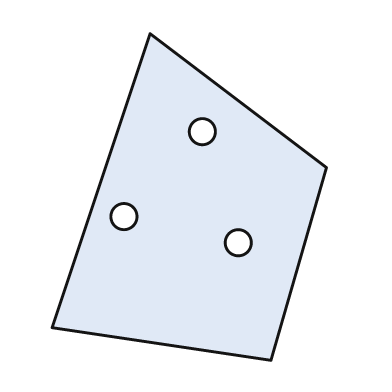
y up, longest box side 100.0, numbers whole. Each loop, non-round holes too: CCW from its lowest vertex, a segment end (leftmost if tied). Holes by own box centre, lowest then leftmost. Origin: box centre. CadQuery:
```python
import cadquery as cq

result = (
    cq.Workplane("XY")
    .moveTo(25.0, -50.0)
    .lineTo(42.0, 9.0)
    .lineTo(-12.0, 50.0)
    .lineTo(-42.0, -40.0)
    .close()
    .moveTo(15.0, -14.0)
    .circle(4.0)
    .moveTo(-20.0, -6.0)
    .circle(4.0)
    .moveTo(4.0, 20.0)
    .circle(4.0)
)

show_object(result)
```